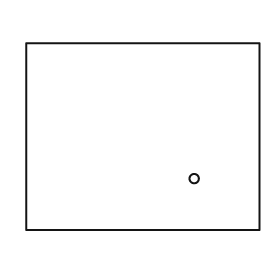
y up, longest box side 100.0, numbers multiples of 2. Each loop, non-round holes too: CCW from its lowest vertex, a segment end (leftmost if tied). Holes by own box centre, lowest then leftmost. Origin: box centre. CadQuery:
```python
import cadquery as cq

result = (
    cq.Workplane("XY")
    .moveTo(-50.0, -40.0)
    .lineTo(50.0, -40.0)
    .lineTo(50.0, 40.0)
    .lineTo(-50.0, 40.0)
    .close()
    .moveTo(22.0, -18.0)
    .circle(2.0)
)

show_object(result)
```